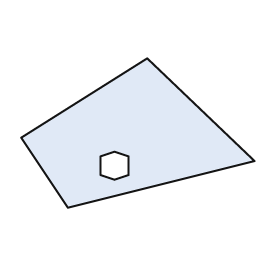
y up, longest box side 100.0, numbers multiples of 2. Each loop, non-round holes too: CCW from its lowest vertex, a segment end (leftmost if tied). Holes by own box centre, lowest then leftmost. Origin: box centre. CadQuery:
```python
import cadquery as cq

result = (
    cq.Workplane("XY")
    .moveTo(-30.0, -32.0)
    .lineTo(50.0, -12.0)
    .lineTo(4.0, 32.0)
    .lineTo(-50.0, -2.0)
    .close()
    .moveTo(-10.0, -20.0)
    .lineTo(-4.0, -18.0)
    .lineTo(-4.0, -10.0)
    .lineTo(-10.0, -8.0)
    .lineTo(-16.0, -10.0)
    .lineTo(-16.0, -18.0)
    .close()
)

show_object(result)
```